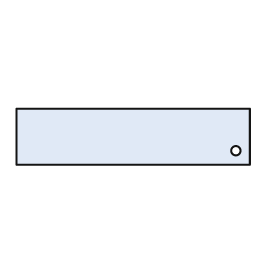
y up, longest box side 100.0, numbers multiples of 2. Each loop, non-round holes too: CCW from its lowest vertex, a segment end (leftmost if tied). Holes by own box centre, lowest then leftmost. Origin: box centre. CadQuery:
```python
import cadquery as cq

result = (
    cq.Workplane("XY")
    .moveTo(-50.0, -12.0)
    .lineTo(50.0, -12.0)
    .lineTo(50.0, 12.0)
    .lineTo(-50.0, 12.0)
    .close()
    .moveTo(44.0, -6.0)
    .circle(2.0)
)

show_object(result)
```